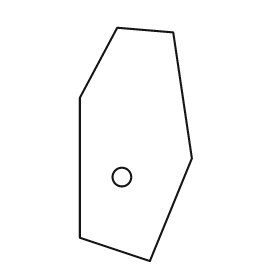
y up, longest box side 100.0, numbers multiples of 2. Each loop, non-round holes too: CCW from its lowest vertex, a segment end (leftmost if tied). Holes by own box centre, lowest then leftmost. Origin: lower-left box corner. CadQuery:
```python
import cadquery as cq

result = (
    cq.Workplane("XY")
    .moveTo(30.0, 0.0)
    .lineTo(48.0, 44.0)
    .lineTo(40.0, 98.0)
    .lineTo(16.0, 100.0)
    .lineTo(0.0, 70.0)
    .lineTo(0.0, 10.0)
    .close()
    .moveTo(18.0, 36.0)
    .circle(4.0)
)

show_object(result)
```